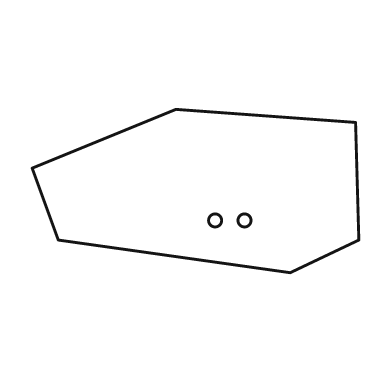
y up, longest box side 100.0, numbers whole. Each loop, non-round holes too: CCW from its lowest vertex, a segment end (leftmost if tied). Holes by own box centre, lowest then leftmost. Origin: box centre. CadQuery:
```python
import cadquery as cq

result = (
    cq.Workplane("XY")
    .moveTo(29.0, -25.0)
    .lineTo(50.0, -15.0)
    .lineTo(49.0, 21.0)
    .lineTo(-6.0, 25.0)
    .lineTo(-50.0, 7.0)
    .lineTo(-42.0, -15.0)
    .close()
    .moveTo(6.0, -9.0)
    .circle(2.0)
    .moveTo(15.0, -9.0)
    .circle(2.0)
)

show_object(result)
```